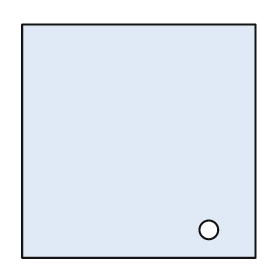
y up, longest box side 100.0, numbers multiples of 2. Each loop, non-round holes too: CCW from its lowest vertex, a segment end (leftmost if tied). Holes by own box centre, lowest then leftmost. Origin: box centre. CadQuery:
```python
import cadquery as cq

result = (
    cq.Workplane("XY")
    .moveTo(-50.0, -50.0)
    .lineTo(50.0, -50.0)
    .lineTo(50.0, 50.0)
    .lineTo(-50.0, 50.0)
    .close()
    .moveTo(30.0, -38.0)
    .circle(4.0)
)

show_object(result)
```